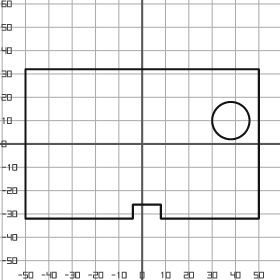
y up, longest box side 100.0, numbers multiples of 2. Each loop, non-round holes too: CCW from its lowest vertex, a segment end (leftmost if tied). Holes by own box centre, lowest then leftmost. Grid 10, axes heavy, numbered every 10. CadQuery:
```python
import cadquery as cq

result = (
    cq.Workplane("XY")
    .moveTo(-50.0, -32.0)
    .lineTo(-4.0, -32.0)
    .lineTo(-4.0, -26.0)
    .lineTo(8.0, -26.0)
    .lineTo(8.0, -32.0)
    .lineTo(50.0, -32.0)
    .lineTo(50.0, 32.0)
    .lineTo(-50.0, 32.0)
    .close()
    .moveTo(38.0, 10.0)
    .circle(8.0)
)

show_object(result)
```